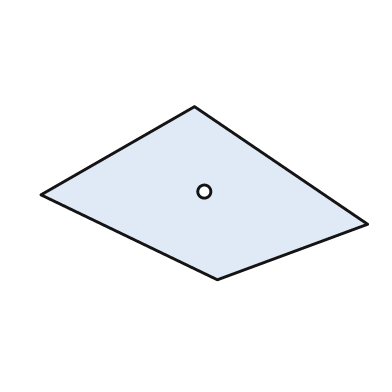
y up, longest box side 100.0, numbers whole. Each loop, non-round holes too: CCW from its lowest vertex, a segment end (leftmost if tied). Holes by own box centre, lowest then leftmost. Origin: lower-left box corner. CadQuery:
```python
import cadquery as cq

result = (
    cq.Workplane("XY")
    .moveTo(54.0, 0.0)
    .lineTo(100.0, 17.0)
    .lineTo(47.0, 53.0)
    .lineTo(0.0, 26.0)
    .close()
    .moveTo(50.0, 27.0)
    .circle(2.0)
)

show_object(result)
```